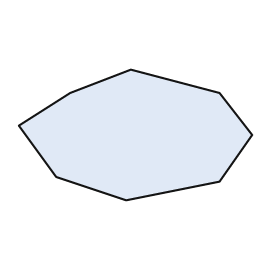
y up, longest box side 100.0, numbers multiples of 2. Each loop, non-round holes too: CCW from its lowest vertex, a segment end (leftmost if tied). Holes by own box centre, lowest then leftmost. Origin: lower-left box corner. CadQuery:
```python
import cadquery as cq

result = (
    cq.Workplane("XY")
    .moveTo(46.0, 0.0)
    .lineTo(86.0, 8.0)
    .lineTo(100.0, 28.0)
    .lineTo(86.0, 46.0)
    .lineTo(48.0, 56.0)
    .lineTo(22.0, 46.0)
    .lineTo(0.0, 32.0)
    .lineTo(16.0, 10.0)
    .close()
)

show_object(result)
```